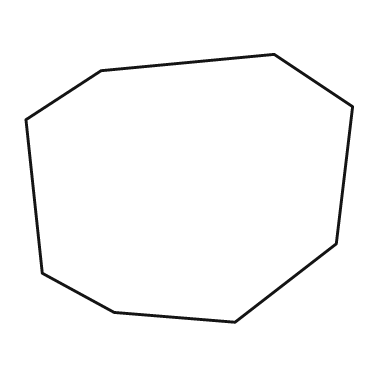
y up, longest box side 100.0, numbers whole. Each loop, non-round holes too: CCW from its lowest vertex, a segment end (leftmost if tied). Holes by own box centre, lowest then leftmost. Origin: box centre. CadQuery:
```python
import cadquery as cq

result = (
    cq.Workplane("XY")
    .moveTo(14.0, -41.0)
    .lineTo(45.0, -17.0)
    .lineTo(50.0, 25.0)
    .lineTo(26.0, 41.0)
    .lineTo(-27.0, 36.0)
    .lineTo(-50.0, 21.0)
    .lineTo(-45.0, -26.0)
    .lineTo(-23.0, -38.0)
    .close()
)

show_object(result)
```